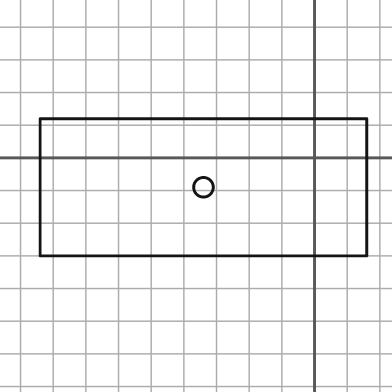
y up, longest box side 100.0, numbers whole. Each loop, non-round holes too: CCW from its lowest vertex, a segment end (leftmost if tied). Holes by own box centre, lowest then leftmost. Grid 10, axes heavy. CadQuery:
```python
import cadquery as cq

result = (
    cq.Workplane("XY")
    .moveTo(-84.0, -30.0)
    .lineTo(16.0, -30.0)
    .lineTo(16.0, 12.0)
    .lineTo(-84.0, 12.0)
    .close()
    .moveTo(-34.0, -9.0)
    .circle(3.0)
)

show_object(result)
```